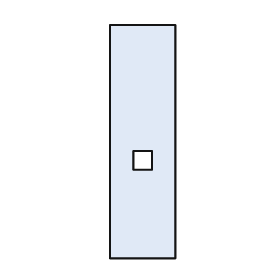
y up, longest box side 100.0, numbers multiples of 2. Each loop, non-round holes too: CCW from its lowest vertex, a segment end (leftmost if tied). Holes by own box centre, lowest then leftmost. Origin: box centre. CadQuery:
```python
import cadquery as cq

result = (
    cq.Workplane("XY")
    .moveTo(-14.0, -50.0)
    .lineTo(14.0, -50.0)
    .lineTo(14.0, 50.0)
    .lineTo(-14.0, 50.0)
    .close()
    .moveTo(-4.0, -12.0)
    .lineTo(4.0, -12.0)
    .lineTo(4.0, -4.0)
    .lineTo(-4.0, -4.0)
    .close()
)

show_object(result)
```